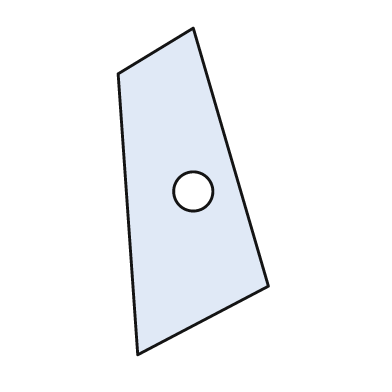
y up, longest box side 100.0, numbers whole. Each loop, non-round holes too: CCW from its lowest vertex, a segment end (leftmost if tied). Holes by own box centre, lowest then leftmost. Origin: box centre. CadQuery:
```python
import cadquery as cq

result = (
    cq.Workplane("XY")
    .moveTo(-17.0, -50.0)
    .lineTo(23.0, -29.0)
    .lineTo(0.0, 50.0)
    .lineTo(-23.0, 36.0)
    .close()
    .moveTo(0.0, 0.0)
    .circle(6.0)
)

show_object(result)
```